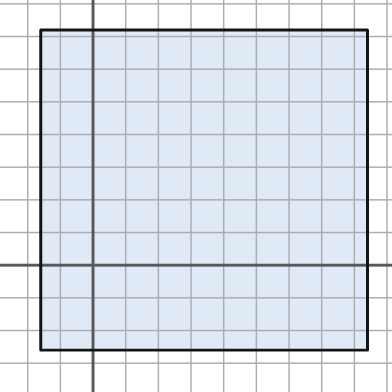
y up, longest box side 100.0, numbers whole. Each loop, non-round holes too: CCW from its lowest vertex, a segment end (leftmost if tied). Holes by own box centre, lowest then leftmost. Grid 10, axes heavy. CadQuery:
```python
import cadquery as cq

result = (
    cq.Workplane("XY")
    .moveTo(-16.0, -26.0)
    .lineTo(84.0, -26.0)
    .lineTo(84.0, 72.0)
    .lineTo(-16.0, 72.0)
    .close()
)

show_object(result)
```